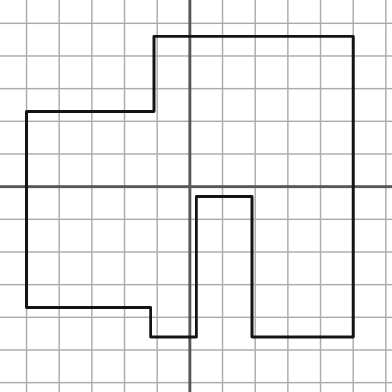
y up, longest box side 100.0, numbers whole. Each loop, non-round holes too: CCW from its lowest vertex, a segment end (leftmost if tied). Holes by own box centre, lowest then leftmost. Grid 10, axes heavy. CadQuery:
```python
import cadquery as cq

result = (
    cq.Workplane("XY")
    .moveTo(-12.0, -46.0)
    .lineTo(2.0, -46.0)
    .lineTo(2.0, -3.0)
    .lineTo(19.0, -3.0)
    .lineTo(19.0, -46.0)
    .lineTo(50.0, -46.0)
    .lineTo(50.0, 46.0)
    .lineTo(-11.0, 46.0)
    .lineTo(-11.0, 23.0)
    .lineTo(-50.0, 23.0)
    .lineTo(-50.0, -37.0)
    .lineTo(-12.0, -37.0)
    .close()
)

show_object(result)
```